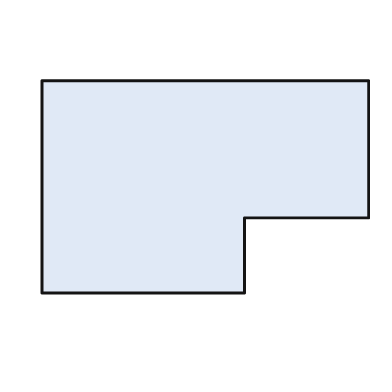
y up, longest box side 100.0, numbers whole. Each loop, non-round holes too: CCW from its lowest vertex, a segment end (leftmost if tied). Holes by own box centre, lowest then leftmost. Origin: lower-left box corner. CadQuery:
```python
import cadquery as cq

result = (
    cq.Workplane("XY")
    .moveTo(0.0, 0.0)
    .lineTo(62.0, 0.0)
    .lineTo(62.0, 23.0)
    .lineTo(100.0, 23.0)
    .lineTo(100.0, 65.0)
    .lineTo(0.0, 65.0)
    .close()
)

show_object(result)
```